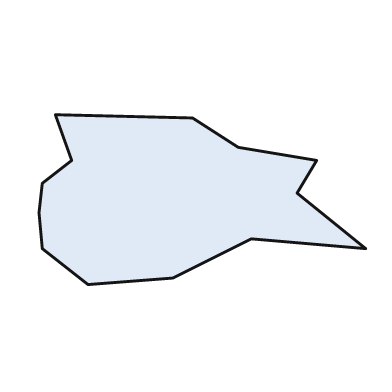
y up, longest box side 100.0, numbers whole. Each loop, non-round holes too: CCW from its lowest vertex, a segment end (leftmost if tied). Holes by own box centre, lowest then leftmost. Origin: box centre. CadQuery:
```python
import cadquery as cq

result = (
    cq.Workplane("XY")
    .moveTo(-35.0, -26.0)
    .lineTo(-9.0, -24.0)
    .lineTo(15.0, -12.0)
    .lineTo(50.0, -15.0)
    .lineTo(29.0, 2.0)
    .lineTo(35.0, 12.0)
    .lineTo(11.0, 16.0)
    .lineTo(-3.0, 25.0)
    .lineTo(-45.0, 26.0)
    .lineTo(-40.0, 12.0)
    .lineTo(-49.0, 5.0)
    .lineTo(-50.0, -4.0)
    .lineTo(-49.0, -15.0)
    .close()
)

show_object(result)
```